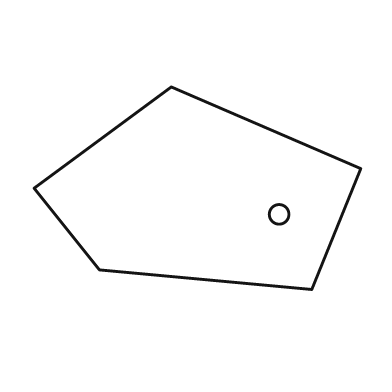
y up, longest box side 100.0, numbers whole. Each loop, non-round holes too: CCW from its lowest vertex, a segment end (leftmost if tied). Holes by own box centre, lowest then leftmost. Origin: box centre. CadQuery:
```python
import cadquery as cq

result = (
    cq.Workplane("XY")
    .moveTo(35.0, -31.0)
    .lineTo(50.0, 6.0)
    .lineTo(-8.0, 31.0)
    .lineTo(-50.0, 0.0)
    .lineTo(-30.0, -25.0)
    .close()
    .moveTo(25.0, -8.0)
    .circle(3.0)
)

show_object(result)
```